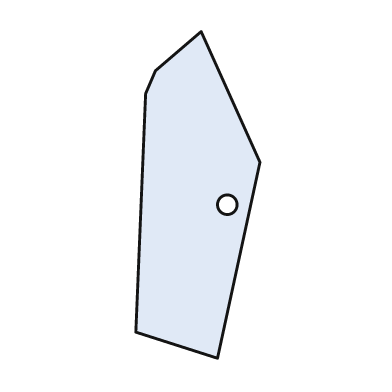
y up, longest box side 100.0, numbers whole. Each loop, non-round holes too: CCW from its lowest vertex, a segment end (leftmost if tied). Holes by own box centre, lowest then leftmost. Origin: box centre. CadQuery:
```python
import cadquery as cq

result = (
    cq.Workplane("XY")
    .moveTo(6.0, -50.0)
    .lineTo(19.0, 10.0)
    .lineTo(1.0, 50.0)
    .lineTo(-13.0, 38.0)
    .lineTo(-16.0, 31.0)
    .lineTo(-19.0, -42.0)
    .close()
    .moveTo(9.0, -3.0)
    .circle(3.0)
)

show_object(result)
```